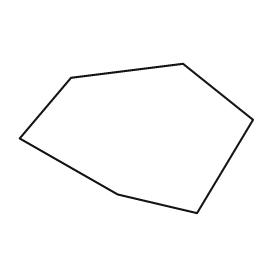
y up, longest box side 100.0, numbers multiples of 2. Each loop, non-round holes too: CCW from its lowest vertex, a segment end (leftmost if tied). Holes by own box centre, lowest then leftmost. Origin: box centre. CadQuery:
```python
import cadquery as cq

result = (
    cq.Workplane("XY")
    .moveTo(26.0, -32.0)
    .lineTo(50.0, 8.0)
    .lineTo(20.0, 32.0)
    .lineTo(-28.0, 26.0)
    .lineTo(-50.0, 0.0)
    .lineTo(-8.0, -24.0)
    .close()
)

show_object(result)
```